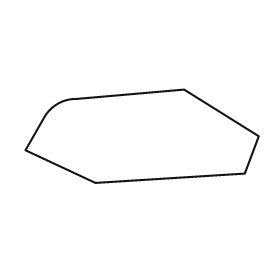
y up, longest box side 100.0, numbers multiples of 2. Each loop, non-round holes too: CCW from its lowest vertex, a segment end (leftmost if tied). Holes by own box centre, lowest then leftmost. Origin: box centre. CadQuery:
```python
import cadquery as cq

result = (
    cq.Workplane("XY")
    .moveTo(-20.0, -20.0)
    .lineTo(44.0, -16.0)
    .lineTo(50.0, 0.0)
    .lineTo(18.0, 20.0)
    .lineTo(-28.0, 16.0)
    .threePointArc((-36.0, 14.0), (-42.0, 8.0))
    .lineTo(-50.0, -6.0)
    .close()
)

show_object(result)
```